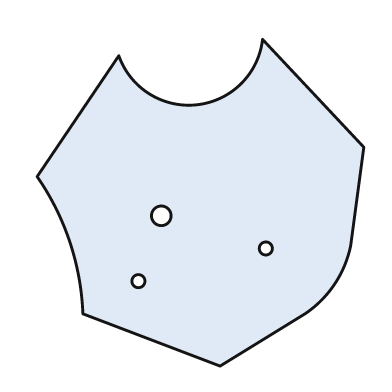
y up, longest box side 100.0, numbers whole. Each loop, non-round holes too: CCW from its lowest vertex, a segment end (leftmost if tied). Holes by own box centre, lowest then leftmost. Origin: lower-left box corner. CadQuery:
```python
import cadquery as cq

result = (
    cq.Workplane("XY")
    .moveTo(56.0, 0.0)
    .lineTo(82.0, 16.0)
    .threePointArc((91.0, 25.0), (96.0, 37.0))
    .lineTo(100.0, 67.0)
    .lineTo(69.0, 100.0)
    .threePointArc((49.0, 80.0), (25.0, 95.0))
    .lineTo(0.0, 58.0)
    .threePointArc((10.0, 38.0), (14.0, 16.0))
    .close()
    .moveTo(31.0, 26.0)
    .circle(2.0)
    .moveTo(70.0, 36.0)
    .circle(2.0)
    .moveTo(38.0, 46.0)
    .circle(3.0)
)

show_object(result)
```